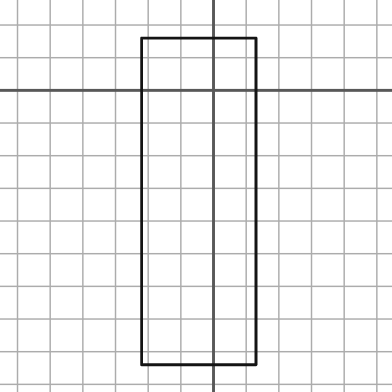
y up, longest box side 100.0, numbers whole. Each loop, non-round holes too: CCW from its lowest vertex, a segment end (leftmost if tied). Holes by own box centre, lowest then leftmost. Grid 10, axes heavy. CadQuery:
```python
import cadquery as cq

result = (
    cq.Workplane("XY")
    .moveTo(-22.0, -84.0)
    .lineTo(13.0, -84.0)
    .lineTo(13.0, 16.0)
    .lineTo(-22.0, 16.0)
    .close()
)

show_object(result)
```